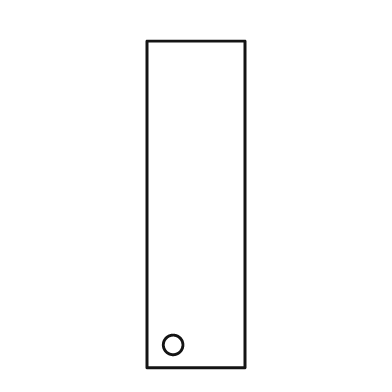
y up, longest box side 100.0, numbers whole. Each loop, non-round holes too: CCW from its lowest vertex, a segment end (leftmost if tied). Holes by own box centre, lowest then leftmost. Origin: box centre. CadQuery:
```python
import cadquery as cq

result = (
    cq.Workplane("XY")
    .moveTo(-15.0, -50.0)
    .lineTo(15.0, -50.0)
    .lineTo(15.0, 50.0)
    .lineTo(-15.0, 50.0)
    .close()
    .moveTo(-7.0, -43.0)
    .circle(3.0)
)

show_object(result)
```